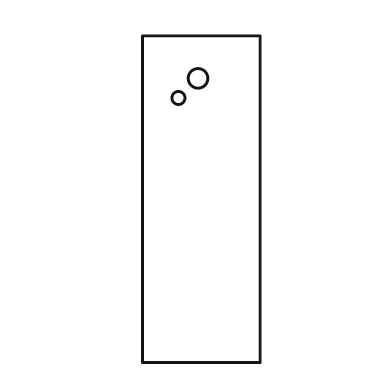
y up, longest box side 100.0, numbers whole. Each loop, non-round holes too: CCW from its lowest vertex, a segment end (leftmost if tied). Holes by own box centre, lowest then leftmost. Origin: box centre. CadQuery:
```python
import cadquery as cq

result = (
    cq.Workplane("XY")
    .moveTo(-18.0, -50.0)
    .lineTo(18.0, -50.0)
    .lineTo(18.0, 50.0)
    .lineTo(-18.0, 50.0)
    .close()
    .moveTo(-7.0, 31.0)
    .circle(2.0)
    .moveTo(-1.0, 37.0)
    .circle(3.0)
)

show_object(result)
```